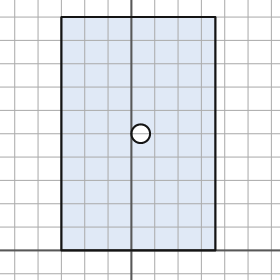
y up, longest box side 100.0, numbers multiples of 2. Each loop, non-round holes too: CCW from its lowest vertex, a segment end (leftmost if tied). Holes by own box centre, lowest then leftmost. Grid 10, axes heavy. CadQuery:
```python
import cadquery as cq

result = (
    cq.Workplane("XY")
    .moveTo(-30.0, 0.0)
    .lineTo(36.0, 0.0)
    .lineTo(36.0, 100.0)
    .lineTo(-30.0, 100.0)
    .close()
    .moveTo(4.0, 50.0)
    .circle(4.0)
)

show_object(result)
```